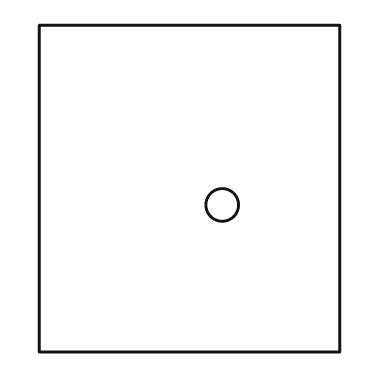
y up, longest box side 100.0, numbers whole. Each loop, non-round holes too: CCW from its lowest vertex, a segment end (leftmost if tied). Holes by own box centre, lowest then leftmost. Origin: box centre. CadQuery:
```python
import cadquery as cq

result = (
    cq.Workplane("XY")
    .moveTo(-46.0, -50.0)
    .lineTo(46.0, -50.0)
    .lineTo(46.0, 50.0)
    .lineTo(-46.0, 50.0)
    .close()
    .moveTo(10.0, -5.0)
    .circle(5.0)
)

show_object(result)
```